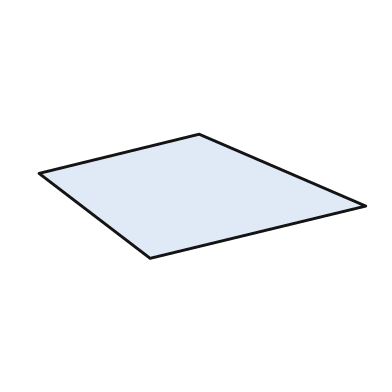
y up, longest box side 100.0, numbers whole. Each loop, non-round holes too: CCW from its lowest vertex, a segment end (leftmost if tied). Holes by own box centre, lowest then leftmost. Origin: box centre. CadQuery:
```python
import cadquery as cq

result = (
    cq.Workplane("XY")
    .moveTo(-16.0, -19.0)
    .lineTo(50.0, -3.0)
    .lineTo(-1.0, 19.0)
    .lineTo(-50.0, 7.0)
    .close()
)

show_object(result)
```